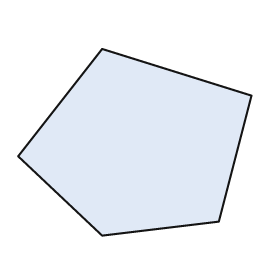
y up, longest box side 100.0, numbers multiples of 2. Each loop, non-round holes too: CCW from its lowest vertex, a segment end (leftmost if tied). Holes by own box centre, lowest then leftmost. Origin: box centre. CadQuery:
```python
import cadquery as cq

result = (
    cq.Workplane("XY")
    .moveTo(-14.0, -40.0)
    .lineTo(36.0, -34.0)
    .lineTo(50.0, 20.0)
    .lineTo(-14.0, 40.0)
    .lineTo(-50.0, -6.0)
    .close()
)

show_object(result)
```